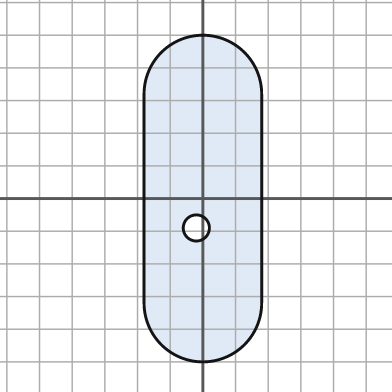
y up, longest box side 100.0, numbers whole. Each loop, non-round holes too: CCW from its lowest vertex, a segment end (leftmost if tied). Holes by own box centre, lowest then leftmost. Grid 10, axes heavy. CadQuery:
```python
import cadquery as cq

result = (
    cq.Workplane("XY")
    .moveTo(-18.0, -32.0)
    .threePointArc((0.0, -50.0), (18.0, -32.0))
    .lineTo(18.0, 32.0)
    .threePointArc((0.0, 50.0), (-18.0, 32.0))
    .close()
    .moveTo(-2.0, -9.0)
    .circle(4.0)
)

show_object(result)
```